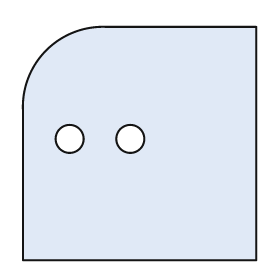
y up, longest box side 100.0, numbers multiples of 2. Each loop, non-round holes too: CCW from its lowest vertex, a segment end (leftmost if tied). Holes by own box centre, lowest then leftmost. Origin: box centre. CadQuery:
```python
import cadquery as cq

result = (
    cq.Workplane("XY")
    .moveTo(-50.0, -50.0)
    .lineTo(50.0, -50.0)
    .lineTo(50.0, 50.0)
    .lineTo(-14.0, 50.0)
    .threePointArc((-40.0, 40.0), (-50.0, 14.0))
    .close()
    .moveTo(-30.0, 2.0)
    .circle(6.0)
    .moveTo(-4.0, 2.0)
    .circle(6.0)
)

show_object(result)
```